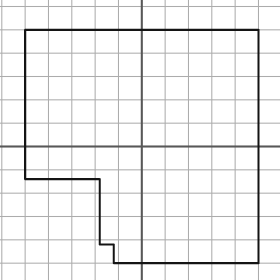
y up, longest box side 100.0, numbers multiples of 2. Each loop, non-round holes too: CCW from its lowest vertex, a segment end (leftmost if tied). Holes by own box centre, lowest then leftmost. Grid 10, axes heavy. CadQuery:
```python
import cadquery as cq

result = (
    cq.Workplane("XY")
    .moveTo(-12.0, -50.0)
    .lineTo(50.0, -50.0)
    .lineTo(50.0, 50.0)
    .lineTo(-50.0, 50.0)
    .lineTo(-50.0, -14.0)
    .lineTo(-18.0, -14.0)
    .lineTo(-18.0, -42.0)
    .lineTo(-12.0, -42.0)
    .close()
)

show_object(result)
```